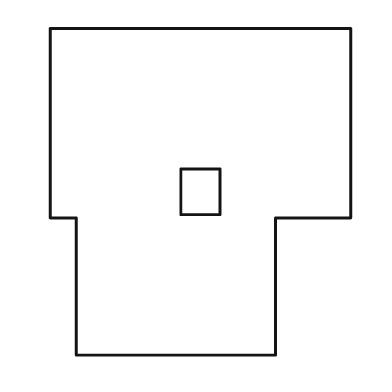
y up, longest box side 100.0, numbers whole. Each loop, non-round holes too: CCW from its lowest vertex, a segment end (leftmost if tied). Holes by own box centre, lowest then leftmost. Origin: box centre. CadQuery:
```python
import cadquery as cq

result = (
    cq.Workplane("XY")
    .moveTo(-38.0, -50.0)
    .lineTo(23.0, -50.0)
    .lineTo(23.0, -8.0)
    .lineTo(46.0, -8.0)
    .lineTo(46.0, 50.0)
    .lineTo(-46.0, 50.0)
    .lineTo(-46.0, -8.0)
    .lineTo(-38.0, -8.0)
    .close()
    .moveTo(-6.0, -7.0)
    .lineTo(6.0, -7.0)
    .lineTo(6.0, 7.0)
    .lineTo(-6.0, 7.0)
    .close()
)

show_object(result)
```